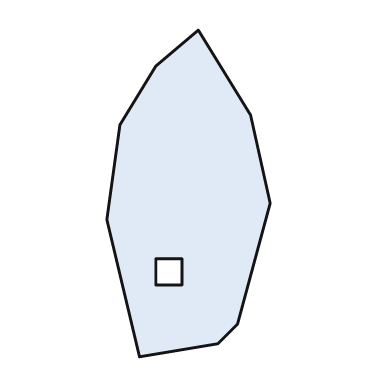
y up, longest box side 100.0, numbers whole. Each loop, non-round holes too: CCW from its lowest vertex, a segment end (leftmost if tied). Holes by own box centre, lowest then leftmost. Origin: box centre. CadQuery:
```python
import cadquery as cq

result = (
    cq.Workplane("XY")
    .moveTo(-15.0, -50.0)
    .lineTo(9.0, -46.0)
    .lineTo(15.0, -40.0)
    .lineTo(25.0, -3.0)
    .lineTo(19.0, 24.0)
    .lineTo(3.0, 50.0)
    .lineTo(-10.0, 39.0)
    .lineTo(-21.0, 21.0)
    .lineTo(-25.0, -8.0)
    .close()
    .moveTo(-10.0, -28.0)
    .lineTo(-2.0, -28.0)
    .lineTo(-2.0, -20.0)
    .lineTo(-10.0, -20.0)
    .close()
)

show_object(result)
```